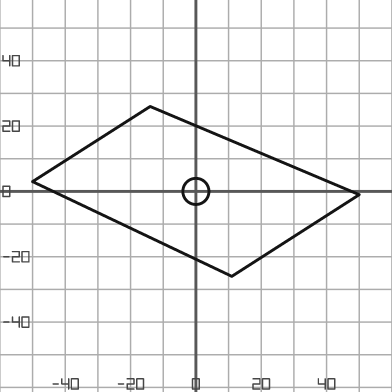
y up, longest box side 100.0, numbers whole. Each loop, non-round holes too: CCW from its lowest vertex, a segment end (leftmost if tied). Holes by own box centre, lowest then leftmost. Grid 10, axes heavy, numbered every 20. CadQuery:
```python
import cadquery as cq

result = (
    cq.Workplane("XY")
    .moveTo(11.0, -26.0)
    .lineTo(50.0, -1.0)
    .lineTo(-14.0, 26.0)
    .lineTo(-50.0, 3.0)
    .close()
    .moveTo(0.0, 0.0)
    .circle(4.0)
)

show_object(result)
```